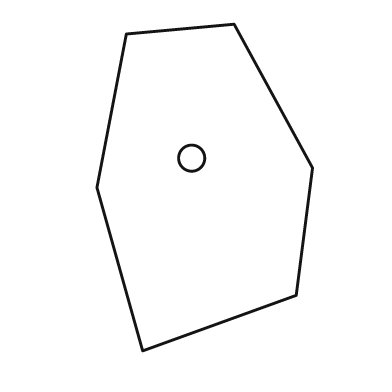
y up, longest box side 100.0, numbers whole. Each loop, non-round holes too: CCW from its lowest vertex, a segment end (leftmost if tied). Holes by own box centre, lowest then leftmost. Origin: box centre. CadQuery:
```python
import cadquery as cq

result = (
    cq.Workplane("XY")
    .moveTo(-19.0, -50.0)
    .lineTo(28.0, -33.0)
    .lineTo(33.0, 6.0)
    .lineTo(9.0, 50.0)
    .lineTo(-24.0, 47.0)
    .lineTo(-33.0, 0.0)
    .close()
    .moveTo(-4.0, 9.0)
    .circle(4.0)
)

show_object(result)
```